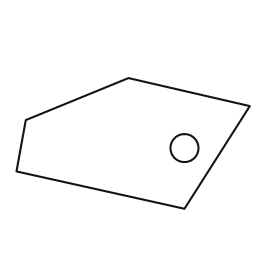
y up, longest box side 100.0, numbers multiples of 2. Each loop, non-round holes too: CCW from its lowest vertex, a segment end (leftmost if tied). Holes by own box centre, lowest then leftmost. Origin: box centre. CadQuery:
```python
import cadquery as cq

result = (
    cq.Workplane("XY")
    .moveTo(22.0, -28.0)
    .lineTo(50.0, 16.0)
    .lineTo(-2.0, 28.0)
    .lineTo(-46.0, 10.0)
    .lineTo(-50.0, -12.0)
    .close()
    .moveTo(22.0, -2.0)
    .circle(6.0)
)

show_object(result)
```